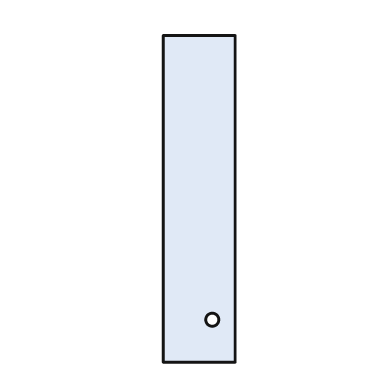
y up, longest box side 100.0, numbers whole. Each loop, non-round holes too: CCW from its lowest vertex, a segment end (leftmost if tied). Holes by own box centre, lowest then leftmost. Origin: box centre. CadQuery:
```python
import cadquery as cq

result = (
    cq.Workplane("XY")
    .moveTo(-11.0, -50.0)
    .lineTo(11.0, -50.0)
    .lineTo(11.0, 50.0)
    .lineTo(-11.0, 50.0)
    .close()
    .moveTo(4.0, -37.0)
    .circle(2.0)
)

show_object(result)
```